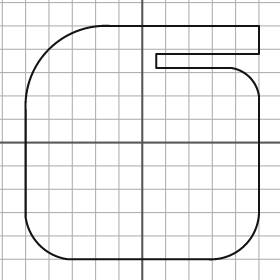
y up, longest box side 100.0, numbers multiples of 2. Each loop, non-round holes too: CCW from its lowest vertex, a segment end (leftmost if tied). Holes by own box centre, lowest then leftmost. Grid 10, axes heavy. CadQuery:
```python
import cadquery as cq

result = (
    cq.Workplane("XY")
    .moveTo(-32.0, -50.0)
    .lineTo(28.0, -50.0)
    .threePointArc((44.0, -44.0), (50.0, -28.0))
    .lineTo(50.0, 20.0)
    .threePointArc((46.0, 28.0), (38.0, 32.0))
    .lineTo(6.0, 32.0)
    .lineTo(6.0, 38.0)
    .lineTo(50.0, 38.0)
    .lineTo(50.0, 50.0)
    .lineTo(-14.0, 50.0)
    .threePointArc((-40.0, 40.0), (-50.0, 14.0))
    .lineTo(-50.0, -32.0)
    .threePointArc((-44.0, -44.0), (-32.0, -50.0))
    .close()
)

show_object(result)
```